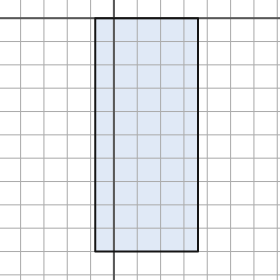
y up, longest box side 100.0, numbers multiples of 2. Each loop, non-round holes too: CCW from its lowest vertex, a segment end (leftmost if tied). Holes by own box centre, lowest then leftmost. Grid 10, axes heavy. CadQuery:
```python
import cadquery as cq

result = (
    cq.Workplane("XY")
    .moveTo(-8.0, -100.0)
    .lineTo(36.0, -100.0)
    .lineTo(36.0, 0.0)
    .lineTo(-8.0, 0.0)
    .close()
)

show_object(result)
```